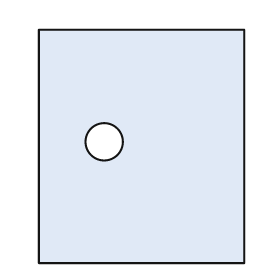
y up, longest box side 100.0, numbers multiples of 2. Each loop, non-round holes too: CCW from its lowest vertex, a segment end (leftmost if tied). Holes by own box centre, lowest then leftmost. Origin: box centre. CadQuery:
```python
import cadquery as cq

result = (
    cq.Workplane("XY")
    .moveTo(-44.0, -50.0)
    .lineTo(44.0, -50.0)
    .lineTo(44.0, 50.0)
    .lineTo(-44.0, 50.0)
    .close()
    .moveTo(-16.0, 2.0)
    .circle(8.0)
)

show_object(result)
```